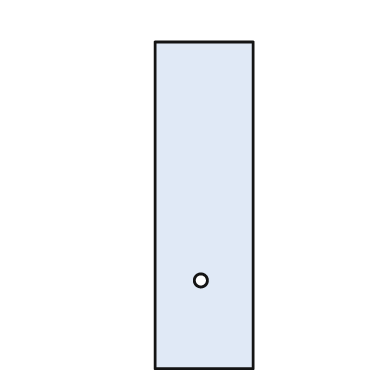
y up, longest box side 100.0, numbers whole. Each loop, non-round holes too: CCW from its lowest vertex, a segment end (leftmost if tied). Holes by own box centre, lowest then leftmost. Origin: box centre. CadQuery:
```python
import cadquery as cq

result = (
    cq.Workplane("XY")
    .moveTo(-15.0, -50.0)
    .lineTo(15.0, -50.0)
    .lineTo(15.0, 50.0)
    .lineTo(-15.0, 50.0)
    .close()
    .moveTo(-1.0, -23.0)
    .circle(2.0)
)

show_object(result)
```